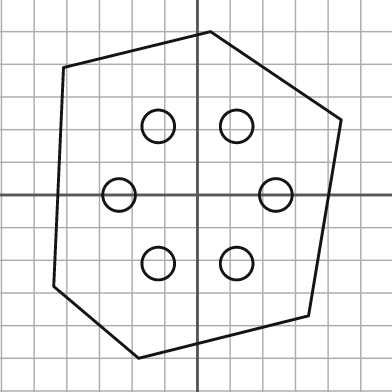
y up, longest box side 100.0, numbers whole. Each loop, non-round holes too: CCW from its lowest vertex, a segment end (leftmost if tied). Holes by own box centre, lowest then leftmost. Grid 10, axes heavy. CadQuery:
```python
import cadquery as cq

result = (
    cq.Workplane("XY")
    .moveTo(-18.0, -50.0)
    .lineTo(34.0, -37.0)
    .lineTo(44.0, 23.0)
    .lineTo(4.0, 50.0)
    .lineTo(-41.0, 39.0)
    .lineTo(-44.0, -28.0)
    .close()
    .moveTo(-12.0, -21.0)
    .circle(5.0)
    .moveTo(12.0, -21.0)
    .circle(5.0)
    .moveTo(-24.0, 0.0)
    .circle(5.0)
    .moveTo(24.0, 0.0)
    .circle(5.0)
    .moveTo(-12.0, 21.0)
    .circle(5.0)
    .moveTo(12.0, 21.0)
    .circle(5.0)
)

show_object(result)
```